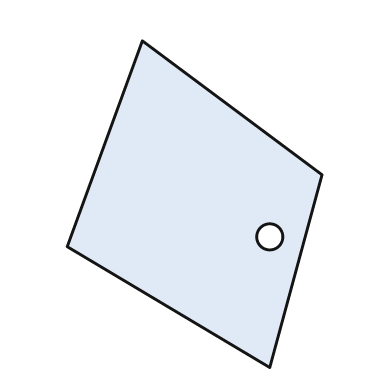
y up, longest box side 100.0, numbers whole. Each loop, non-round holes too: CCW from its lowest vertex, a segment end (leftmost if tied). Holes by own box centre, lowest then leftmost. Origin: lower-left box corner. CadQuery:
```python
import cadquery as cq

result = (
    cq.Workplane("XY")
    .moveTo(62.0, 0.0)
    .lineTo(78.0, 59.0)
    .lineTo(23.0, 100.0)
    .lineTo(0.0, 37.0)
    .close()
    .moveTo(62.0, 40.0)
    .circle(4.0)
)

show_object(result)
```